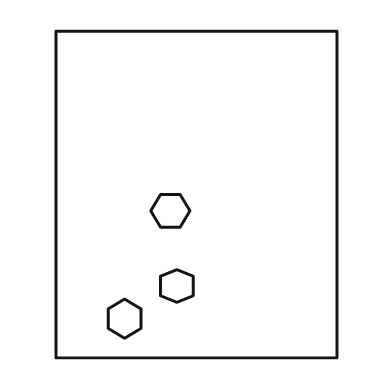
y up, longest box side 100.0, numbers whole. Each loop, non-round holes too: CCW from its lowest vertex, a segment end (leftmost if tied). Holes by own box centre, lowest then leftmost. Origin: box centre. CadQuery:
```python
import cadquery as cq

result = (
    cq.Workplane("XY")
    .moveTo(-43.0, -50.0)
    .lineTo(43.0, -50.0)
    .lineTo(43.0, 50.0)
    .lineTo(-43.0, 50.0)
    .close()
    .moveTo(-22.0, -44.0)
    .lineTo(-17.0, -41.0)
    .lineTo(-17.0, -35.0)
    .lineTo(-22.0, -32.0)
    .lineTo(-27.0, -35.0)
    .lineTo(-27.0, -41.0)
    .close()
    .moveTo(-6.0, -33.0)
    .lineTo(-1.0, -31.0)
    .lineTo(-1.0, -25.0)
    .lineTo(-6.0, -23.0)
    .lineTo(-11.0, -25.0)
    .lineTo(-11.0, -31.0)
    .close()
    .moveTo(-11.0, -10.0)
    .lineTo(-5.0, -10.0)
    .lineTo(-2.0, -5.0)
    .lineTo(-5.0, 0.0)
    .lineTo(-11.0, 0.0)
    .lineTo(-14.0, -5.0)
    .close()
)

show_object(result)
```